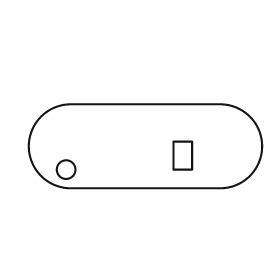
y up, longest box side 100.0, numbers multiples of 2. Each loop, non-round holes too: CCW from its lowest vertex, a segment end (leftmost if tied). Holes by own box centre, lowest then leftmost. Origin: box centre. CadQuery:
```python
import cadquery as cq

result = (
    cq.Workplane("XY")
    .moveTo(-32.0, -18.0)
    .lineTo(32.0, -18.0)
    .threePointArc((50.0, 0.0), (32.0, 18.0))
    .lineTo(-32.0, 18.0)
    .threePointArc((-50.0, 0.0), (-32.0, -18.0))
    .close()
    .moveTo(-34.0, -10.0)
    .circle(4.0)
    .moveTo(12.0, -10.0)
    .lineTo(20.0, -10.0)
    .lineTo(20.0, 2.0)
    .lineTo(12.0, 2.0)
    .close()
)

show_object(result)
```